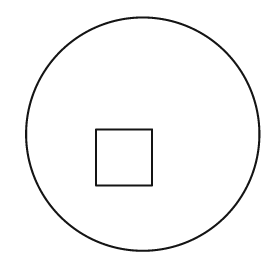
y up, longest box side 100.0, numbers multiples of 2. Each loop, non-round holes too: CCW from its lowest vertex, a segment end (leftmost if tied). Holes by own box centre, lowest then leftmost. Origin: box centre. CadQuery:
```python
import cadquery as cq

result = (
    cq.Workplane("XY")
    .moveTo(0.0, 0.0)
    .circle(50.0)
    .moveTo(-20.0, -22.0)
    .lineTo(4.0, -22.0)
    .lineTo(4.0, 2.0)
    .lineTo(-20.0, 2.0)
    .close()
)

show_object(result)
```